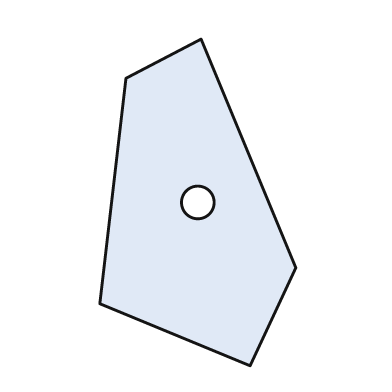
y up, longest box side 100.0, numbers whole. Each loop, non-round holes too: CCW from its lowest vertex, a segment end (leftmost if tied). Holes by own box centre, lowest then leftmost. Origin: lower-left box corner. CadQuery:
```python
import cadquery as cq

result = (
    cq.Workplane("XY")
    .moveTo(46.0, 0.0)
    .lineTo(60.0, 30.0)
    .lineTo(31.0, 100.0)
    .lineTo(8.0, 88.0)
    .lineTo(0.0, 19.0)
    .close()
    .moveTo(30.0, 50.0)
    .circle(5.0)
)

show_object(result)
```